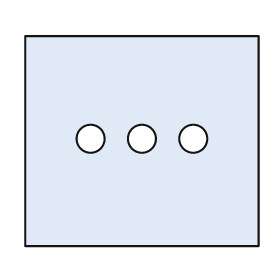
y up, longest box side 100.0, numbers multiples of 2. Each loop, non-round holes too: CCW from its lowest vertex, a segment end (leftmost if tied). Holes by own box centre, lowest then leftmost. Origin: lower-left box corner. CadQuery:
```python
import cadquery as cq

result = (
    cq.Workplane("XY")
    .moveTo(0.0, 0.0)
    .lineTo(100.0, 0.0)
    .lineTo(100.0, 90.0)
    .lineTo(0.0, 90.0)
    .close()
    .moveTo(28.0, 46.0)
    .circle(6.0)
    .moveTo(50.0, 46.0)
    .circle(6.0)
    .moveTo(72.0, 46.0)
    .circle(6.0)
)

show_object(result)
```